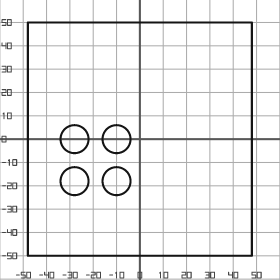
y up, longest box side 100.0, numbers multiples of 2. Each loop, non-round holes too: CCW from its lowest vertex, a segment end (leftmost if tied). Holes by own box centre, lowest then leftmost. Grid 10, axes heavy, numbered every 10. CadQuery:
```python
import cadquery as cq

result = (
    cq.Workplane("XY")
    .moveTo(-48.0, -50.0)
    .lineTo(48.0, -50.0)
    .lineTo(48.0, 50.0)
    .lineTo(-48.0, 50.0)
    .close()
    .moveTo(-28.0, -18.0)
    .circle(6.0)
    .moveTo(-10.0, -18.0)
    .circle(6.0)
    .moveTo(-28.0, 0.0)
    .circle(6.0)
    .moveTo(-10.0, 0.0)
    .circle(6.0)
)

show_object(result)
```